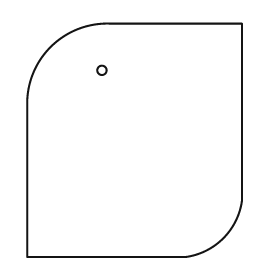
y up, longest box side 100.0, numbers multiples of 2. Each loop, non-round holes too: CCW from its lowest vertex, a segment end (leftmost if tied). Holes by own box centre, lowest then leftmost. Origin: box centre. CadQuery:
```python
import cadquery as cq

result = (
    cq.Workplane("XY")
    .moveTo(-46.0, -50.0)
    .lineTo(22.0, -50.0)
    .threePointArc((38.0, -42.0), (46.0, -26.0))
    .lineTo(46.0, 50.0)
    .lineTo(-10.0, 50.0)
    .threePointArc((-36.0, 40.0), (-46.0, 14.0))
    .close()
    .moveTo(-14.0, 30.0)
    .circle(2.0)
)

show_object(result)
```